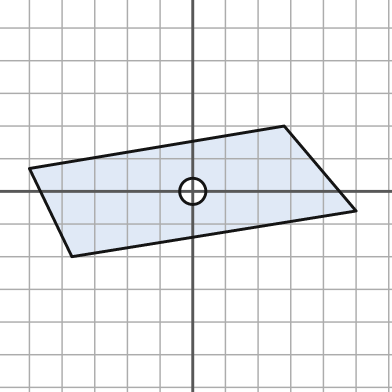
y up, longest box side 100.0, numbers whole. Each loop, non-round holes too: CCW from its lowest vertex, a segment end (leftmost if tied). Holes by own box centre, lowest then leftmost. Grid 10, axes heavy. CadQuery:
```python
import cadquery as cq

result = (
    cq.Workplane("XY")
    .moveTo(-37.0, -20.0)
    .lineTo(50.0, -6.0)
    .lineTo(28.0, 20.0)
    .lineTo(-50.0, 7.0)
    .close()
    .moveTo(0.0, 0.0)
    .circle(4.0)
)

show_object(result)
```